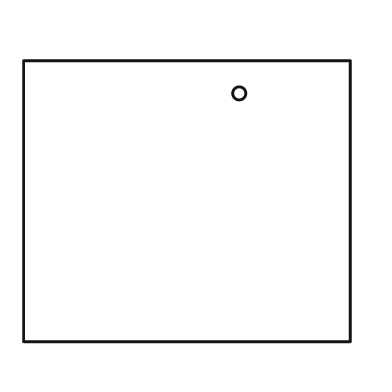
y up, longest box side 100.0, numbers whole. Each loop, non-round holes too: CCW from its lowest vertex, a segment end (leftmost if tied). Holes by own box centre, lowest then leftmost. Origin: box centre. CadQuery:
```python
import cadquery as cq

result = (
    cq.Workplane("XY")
    .moveTo(-50.0, -43.0)
    .lineTo(50.0, -43.0)
    .lineTo(50.0, 43.0)
    .lineTo(-50.0, 43.0)
    .close()
    .moveTo(16.0, 33.0)
    .circle(2.0)
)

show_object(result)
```